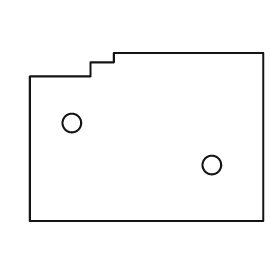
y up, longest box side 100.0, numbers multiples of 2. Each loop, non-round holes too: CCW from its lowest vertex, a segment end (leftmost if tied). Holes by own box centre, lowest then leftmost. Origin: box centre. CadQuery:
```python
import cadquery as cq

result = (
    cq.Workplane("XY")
    .moveTo(-50.0, -36.0)
    .lineTo(50.0, -36.0)
    .lineTo(50.0, 36.0)
    .lineTo(-14.0, 36.0)
    .lineTo(-14.0, 32.0)
    .lineTo(-24.0, 32.0)
    .lineTo(-24.0, 26.0)
    .lineTo(-50.0, 26.0)
    .close()
    .moveTo(28.0, -12.0)
    .circle(4.0)
    .moveTo(-32.0, 6.0)
    .circle(4.0)
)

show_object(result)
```